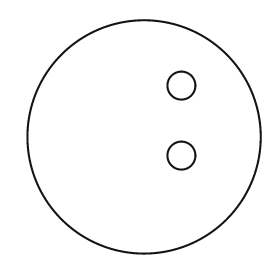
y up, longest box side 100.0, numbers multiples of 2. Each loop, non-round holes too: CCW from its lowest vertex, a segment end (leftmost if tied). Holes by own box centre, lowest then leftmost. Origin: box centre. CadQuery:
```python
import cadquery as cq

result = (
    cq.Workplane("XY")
    .moveTo(0.0, 0.0)
    .circle(50.0)
    .moveTo(16.0, -8.0)
    .circle(6.0)
    .moveTo(16.0, 22.0)
    .circle(6.0)
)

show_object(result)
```